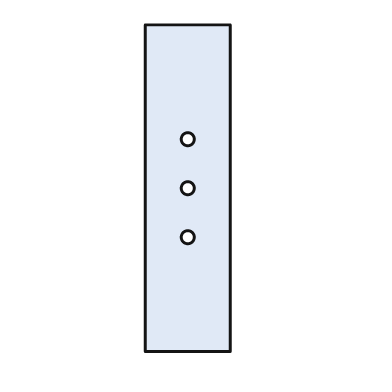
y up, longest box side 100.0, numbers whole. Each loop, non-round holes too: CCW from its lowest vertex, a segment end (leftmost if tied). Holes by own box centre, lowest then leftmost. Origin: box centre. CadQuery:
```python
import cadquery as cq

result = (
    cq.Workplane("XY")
    .moveTo(-13.0, -50.0)
    .lineTo(13.0, -50.0)
    .lineTo(13.0, 50.0)
    .lineTo(-13.0, 50.0)
    .close()
    .moveTo(0.0, -15.0)
    .circle(2.0)
    .moveTo(0.0, 0.0)
    .circle(2.0)
    .moveTo(0.0, 15.0)
    .circle(2.0)
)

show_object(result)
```